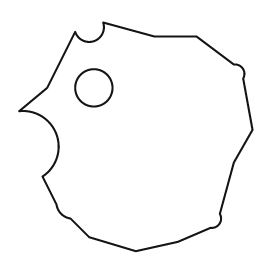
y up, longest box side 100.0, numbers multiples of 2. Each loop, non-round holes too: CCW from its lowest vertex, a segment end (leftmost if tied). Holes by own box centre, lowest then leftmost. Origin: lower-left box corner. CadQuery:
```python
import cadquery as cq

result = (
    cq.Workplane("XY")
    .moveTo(50.0, 0.0)
    .lineTo(68.0, 4.0)
    .lineTo(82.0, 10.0)
    .threePointArc((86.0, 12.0), (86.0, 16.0))
    .lineTo(92.0, 38.0)
    .lineTo(100.0, 52.0)
    .lineTo(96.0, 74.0)
    .threePointArc((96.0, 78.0), (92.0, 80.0))
    .lineTo(76.0, 92.0)
    .lineTo(58.0, 92.0)
    .lineTo(36.0, 98.0)
    .threePointArc((32.0, 90.0), (24.0, 94.0))
    .lineTo(12.0, 70.0)
    .lineTo(0.0, 60.0)
    .threePointArc((16.0, 50.0), (10.0, 32.0))
    .lineTo(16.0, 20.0)
    .threePointArc((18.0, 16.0), (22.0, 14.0))
    .lineTo(30.0, 6.0)
    .close()
    .moveTo(32.0, 70.0)
    .circle(8.0)
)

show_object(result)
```